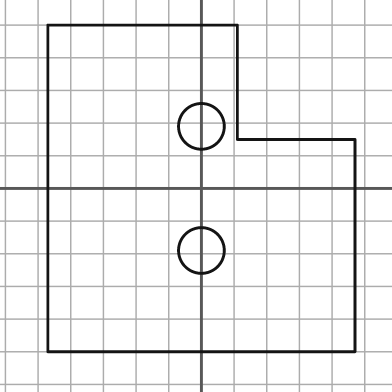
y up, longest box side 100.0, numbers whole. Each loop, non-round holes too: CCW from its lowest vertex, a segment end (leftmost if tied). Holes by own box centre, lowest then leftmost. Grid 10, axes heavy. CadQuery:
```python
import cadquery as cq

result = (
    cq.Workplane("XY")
    .moveTo(-47.0, -50.0)
    .lineTo(47.0, -50.0)
    .lineTo(47.0, 15.0)
    .lineTo(11.0, 15.0)
    .lineTo(11.0, 50.0)
    .lineTo(-47.0, 50.0)
    .close()
    .moveTo(0.0, -19.0)
    .circle(7.0)
    .moveTo(0.0, 19.0)
    .circle(7.0)
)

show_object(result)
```